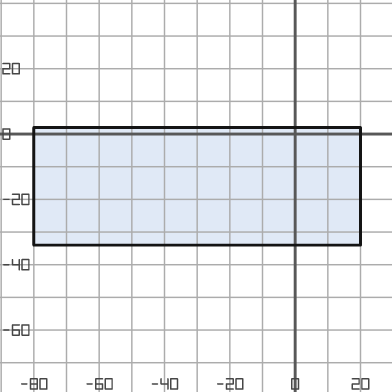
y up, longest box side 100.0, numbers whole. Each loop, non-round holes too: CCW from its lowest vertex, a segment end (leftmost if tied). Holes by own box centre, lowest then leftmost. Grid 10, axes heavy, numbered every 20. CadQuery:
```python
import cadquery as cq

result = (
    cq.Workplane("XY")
    .moveTo(-80.0, -34.0)
    .lineTo(20.0, -34.0)
    .lineTo(20.0, 2.0)
    .lineTo(-80.0, 2.0)
    .close()
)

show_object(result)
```